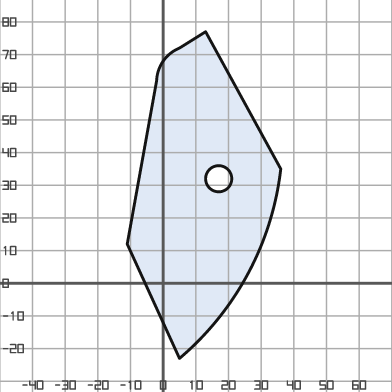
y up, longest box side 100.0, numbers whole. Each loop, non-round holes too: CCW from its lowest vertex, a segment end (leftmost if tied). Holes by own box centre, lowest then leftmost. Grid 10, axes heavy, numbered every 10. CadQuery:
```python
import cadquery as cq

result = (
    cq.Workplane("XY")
    .moveTo(5.0, -23.0)
    .threePointArc((26.0, 3.0), (36.0, 35.0))
    .lineTo(13.0, 77.0)
    .lineTo(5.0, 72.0)
    .threePointArc((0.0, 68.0), (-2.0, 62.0))
    .lineTo(-11.0, 12.0)
    .close()
    .moveTo(17.0, 32.0)
    .circle(4.0)
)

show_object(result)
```